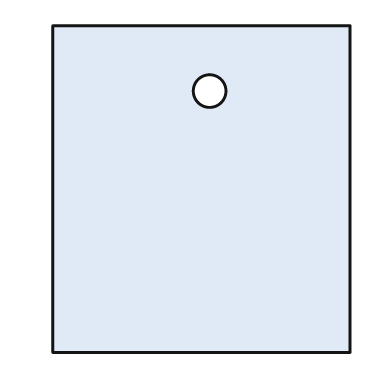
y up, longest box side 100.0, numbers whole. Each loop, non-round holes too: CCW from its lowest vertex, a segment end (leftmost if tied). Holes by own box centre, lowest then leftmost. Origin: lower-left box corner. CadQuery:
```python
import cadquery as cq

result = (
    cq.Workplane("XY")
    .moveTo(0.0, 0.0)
    .lineTo(91.0, 0.0)
    .lineTo(91.0, 100.0)
    .lineTo(0.0, 100.0)
    .close()
    .moveTo(48.0, 80.0)
    .circle(5.0)
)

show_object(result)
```